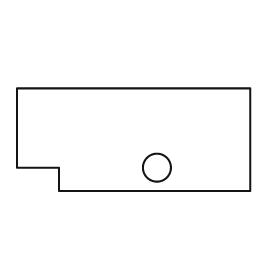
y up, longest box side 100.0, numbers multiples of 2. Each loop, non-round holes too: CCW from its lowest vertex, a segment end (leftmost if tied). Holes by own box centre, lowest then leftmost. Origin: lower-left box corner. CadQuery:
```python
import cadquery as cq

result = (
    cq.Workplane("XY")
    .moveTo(18.0, 0.0)
    .lineTo(100.0, 0.0)
    .lineTo(100.0, 44.0)
    .lineTo(0.0, 44.0)
    .lineTo(0.0, 10.0)
    .lineTo(18.0, 10.0)
    .close()
    .moveTo(60.0, 10.0)
    .circle(6.0)
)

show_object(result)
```